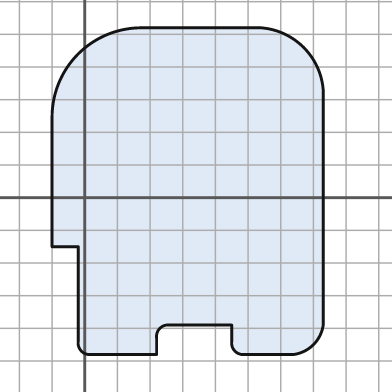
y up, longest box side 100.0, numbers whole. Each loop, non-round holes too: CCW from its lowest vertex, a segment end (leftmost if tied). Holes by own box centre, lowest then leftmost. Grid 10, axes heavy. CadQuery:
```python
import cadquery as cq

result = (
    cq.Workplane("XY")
    .moveTo(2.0, -48.0)
    .lineTo(22.0, -48.0)
    .lineTo(22.0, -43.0)
    .threePointArc((23.0, -40.0), (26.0, -39.0))
    .lineTo(45.0, -39.0)
    .lineTo(45.0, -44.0)
    .threePointArc((46.0, -47.0), (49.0, -48.0))
    .lineTo(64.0, -48.0)
    .threePointArc((70.0, -45.0), (73.0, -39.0))
    .lineTo(73.0, 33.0)
    .threePointArc((67.0, 46.0), (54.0, 52.0))
    .lineTo(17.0, 52.0)
    .threePointArc((-2.0, 44.0), (-10.0, 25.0))
    .lineTo(-10.0, -15.0)
    .lineTo(-2.0, -15.0)
    .lineTo(-2.0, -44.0)
    .threePointArc((-1.0, -47.0), (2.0, -48.0))
    .close()
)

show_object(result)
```